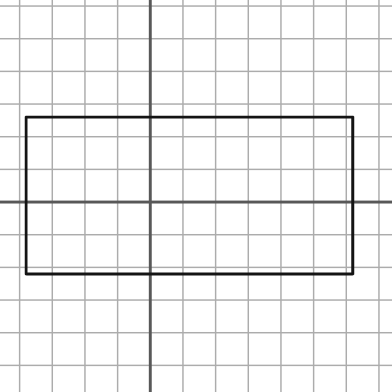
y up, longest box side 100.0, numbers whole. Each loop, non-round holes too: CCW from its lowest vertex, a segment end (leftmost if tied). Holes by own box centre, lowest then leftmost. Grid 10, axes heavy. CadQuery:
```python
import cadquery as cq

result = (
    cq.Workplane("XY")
    .moveTo(-38.0, -22.0)
    .lineTo(62.0, -22.0)
    .lineTo(62.0, 26.0)
    .lineTo(-38.0, 26.0)
    .close()
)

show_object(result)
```